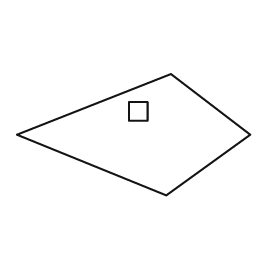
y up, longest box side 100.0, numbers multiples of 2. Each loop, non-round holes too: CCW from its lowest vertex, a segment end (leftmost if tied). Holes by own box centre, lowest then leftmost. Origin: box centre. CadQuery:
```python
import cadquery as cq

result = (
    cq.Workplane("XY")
    .moveTo(14.0, -26.0)
    .lineTo(50.0, 0.0)
    .lineTo(16.0, 26.0)
    .lineTo(-50.0, 0.0)
    .close()
    .moveTo(-2.0, 6.0)
    .lineTo(6.0, 6.0)
    .lineTo(6.0, 14.0)
    .lineTo(-2.0, 14.0)
    .close()
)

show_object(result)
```